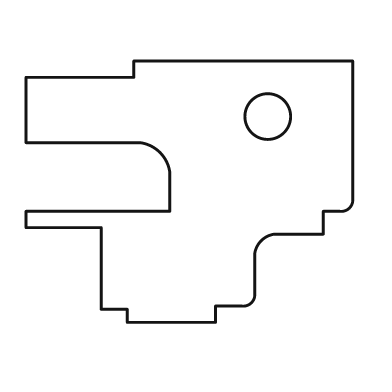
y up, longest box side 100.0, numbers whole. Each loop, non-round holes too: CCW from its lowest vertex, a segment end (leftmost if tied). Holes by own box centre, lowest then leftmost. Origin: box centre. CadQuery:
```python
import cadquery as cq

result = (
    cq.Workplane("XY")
    .moveTo(-19.0, -40.0)
    .lineTo(8.0, -40.0)
    .lineTo(8.0, -35.0)
    .lineTo(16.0, -35.0)
    .threePointArc((19.0, -34.0), (20.0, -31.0))
    .lineTo(20.0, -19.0)
    .threePointArc((22.0, -15.0), (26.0, -13.0))
    .lineTo(41.0, -13.0)
    .lineTo(41.0, -6.0)
    .lineTo(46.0, -6.0)
    .threePointArc((49.0, -5.0), (50.0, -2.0))
    .lineTo(50.0, 40.0)
    .lineTo(-17.0, 40.0)
    .lineTo(-17.0, 35.0)
    .lineTo(-50.0, 35.0)
    .lineTo(-50.0, 15.0)
    .lineTo(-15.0, 15.0)
    .threePointArc((-9.0, 12.0), (-6.0, 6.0))
    .lineTo(-6.0, -6.0)
    .lineTo(-50.0, -6.0)
    .lineTo(-50.0, -11.0)
    .lineTo(-27.0, -11.0)
    .lineTo(-27.0, -36.0)
    .lineTo(-19.0, -36.0)
    .close()
    .moveTo(24.0, 23.0)
    .circle(7.0)
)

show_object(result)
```